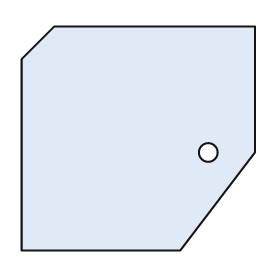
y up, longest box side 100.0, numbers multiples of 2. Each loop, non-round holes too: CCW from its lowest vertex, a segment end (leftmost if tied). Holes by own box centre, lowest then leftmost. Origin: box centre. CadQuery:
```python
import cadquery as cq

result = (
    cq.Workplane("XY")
    .moveTo(-50.0, -48.0)
    .lineTo(18.0, -48.0)
    .lineTo(50.0, -6.0)
    .lineTo(50.0, 48.0)
    .lineTo(-36.0, 48.0)
    .lineTo(-50.0, 34.0)
    .close()
    .moveTo(30.0, -6.0)
    .circle(4.0)
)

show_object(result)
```